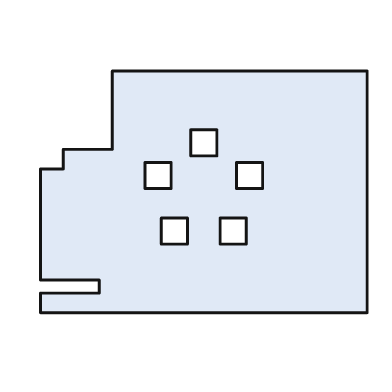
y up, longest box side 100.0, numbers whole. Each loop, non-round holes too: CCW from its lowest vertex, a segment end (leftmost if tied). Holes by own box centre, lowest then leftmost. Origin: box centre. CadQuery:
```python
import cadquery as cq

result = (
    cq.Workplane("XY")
    .moveTo(-50.0, -37.0)
    .lineTo(50.0, -37.0)
    .lineTo(50.0, 37.0)
    .lineTo(-28.0, 37.0)
    .lineTo(-28.0, 13.0)
    .lineTo(-43.0, 13.0)
    .lineTo(-43.0, 7.0)
    .lineTo(-50.0, 7.0)
    .lineTo(-50.0, -27.0)
    .lineTo(-32.0, -27.0)
    .lineTo(-32.0, -31.0)
    .lineTo(-50.0, -31.0)
    .close()
    .moveTo(-13.0, -16.0)
    .lineTo(-5.0, -16.0)
    .lineTo(-5.0, -8.0)
    .lineTo(-13.0, -8.0)
    .close()
    .moveTo(5.0, -16.0)
    .lineTo(13.0, -16.0)
    .lineTo(13.0, -8.0)
    .lineTo(5.0, -8.0)
    .close()
    .moveTo(-18.0, 1.0)
    .lineTo(-10.0, 1.0)
    .lineTo(-10.0, 9.0)
    .lineTo(-18.0, 9.0)
    .close()
    .moveTo(10.0, 1.0)
    .lineTo(18.0, 1.0)
    .lineTo(18.0, 9.0)
    .lineTo(10.0, 9.0)
    .close()
    .moveTo(-4.0, 11.0)
    .lineTo(4.0, 11.0)
    .lineTo(4.0, 19.0)
    .lineTo(-4.0, 19.0)
    .close()
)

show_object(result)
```